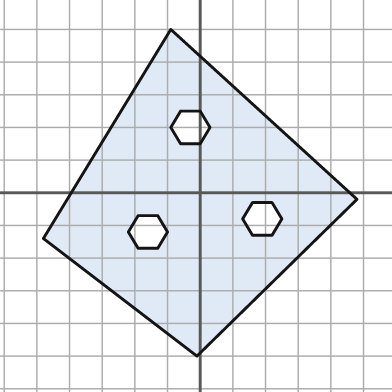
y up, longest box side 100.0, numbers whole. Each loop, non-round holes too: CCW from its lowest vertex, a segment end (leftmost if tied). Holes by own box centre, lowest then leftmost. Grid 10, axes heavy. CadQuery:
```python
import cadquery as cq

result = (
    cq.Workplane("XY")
    .moveTo(-1.0, -50.0)
    .lineTo(48.0, -2.0)
    .lineTo(-9.0, 50.0)
    .lineTo(-48.0, -14.0)
    .close()
    .moveTo(-19.0, -17.0)
    .lineTo(-13.0, -17.0)
    .lineTo(-10.0, -12.0)
    .lineTo(-13.0, -7.0)
    .lineTo(-19.0, -7.0)
    .lineTo(-22.0, -12.0)
    .close()
    .moveTo(16.0, -13.0)
    .lineTo(22.0, -13.0)
    .lineTo(25.0, -8.0)
    .lineTo(22.0, -3.0)
    .lineTo(16.0, -3.0)
    .lineTo(13.0, -8.0)
    .close()
    .moveTo(-6.0, 15.0)
    .lineTo(0.0, 15.0)
    .lineTo(3.0, 20.0)
    .lineTo(0.0, 25.0)
    .lineTo(-6.0, 25.0)
    .lineTo(-9.0, 20.0)
    .close()
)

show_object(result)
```